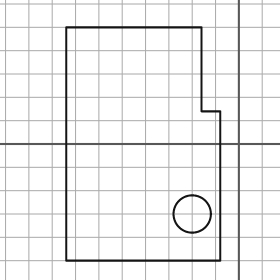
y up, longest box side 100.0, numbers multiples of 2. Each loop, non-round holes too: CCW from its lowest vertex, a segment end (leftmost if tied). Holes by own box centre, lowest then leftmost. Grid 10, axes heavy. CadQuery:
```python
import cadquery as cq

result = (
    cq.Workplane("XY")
    .moveTo(-74.0, -50.0)
    .lineTo(-8.0, -50.0)
    .lineTo(-8.0, 14.0)
    .lineTo(-16.0, 14.0)
    .lineTo(-16.0, 50.0)
    .lineTo(-74.0, 50.0)
    .close()
    .moveTo(-20.0, -30.0)
    .circle(8.0)
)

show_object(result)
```